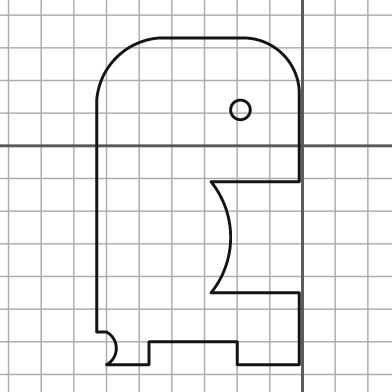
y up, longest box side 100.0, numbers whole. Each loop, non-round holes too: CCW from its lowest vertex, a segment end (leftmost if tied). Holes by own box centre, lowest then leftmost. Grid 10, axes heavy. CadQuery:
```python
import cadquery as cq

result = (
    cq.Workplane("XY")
    .moveTo(-60.0, -67.0)
    .lineTo(-47.0, -67.0)
    .lineTo(-47.0, -60.0)
    .lineTo(-20.0, -60.0)
    .lineTo(-20.0, -67.0)
    .lineTo(-1.0, -67.0)
    .lineTo(-1.0, -45.0)
    .lineTo(-28.0, -45.0)
    .threePointArc((-22.0, -28.0), (-28.0, -11.0))
    .lineTo(-1.0, -11.0)
    .lineTo(-1.0, 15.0)
    .threePointArc((-6.0, 28.0), (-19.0, 33.0))
    .lineTo(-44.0, 33.0)
    .threePointArc((-57.0, 27.0), (-63.0, 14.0))
    .lineTo(-63.0, -57.0)
    .lineTo(-60.0, -57.0)
    .threePointArc((-57.0, -62.0), (-60.0, -67.0))
    .close()
    .moveTo(-19.0, 11.0)
    .circle(3.0)
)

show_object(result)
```